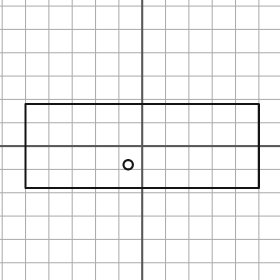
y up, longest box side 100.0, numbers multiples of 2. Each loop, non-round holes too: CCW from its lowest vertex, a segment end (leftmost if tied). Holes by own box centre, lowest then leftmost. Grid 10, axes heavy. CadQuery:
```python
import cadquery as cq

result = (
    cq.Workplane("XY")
    .moveTo(-50.0, -18.0)
    .lineTo(50.0, -18.0)
    .lineTo(50.0, 18.0)
    .lineTo(-50.0, 18.0)
    .close()
    .moveTo(-6.0, -8.0)
    .circle(2.0)
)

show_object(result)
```